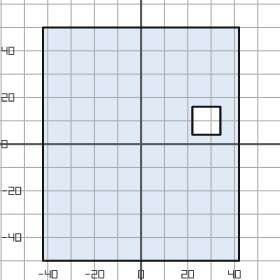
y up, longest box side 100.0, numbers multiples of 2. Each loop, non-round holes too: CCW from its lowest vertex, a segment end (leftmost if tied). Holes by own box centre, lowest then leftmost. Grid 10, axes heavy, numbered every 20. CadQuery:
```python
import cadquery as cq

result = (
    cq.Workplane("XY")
    .moveTo(-42.0, -50.0)
    .lineTo(42.0, -50.0)
    .lineTo(42.0, 50.0)
    .lineTo(-42.0, 50.0)
    .close()
    .moveTo(22.0, 4.0)
    .lineTo(34.0, 4.0)
    .lineTo(34.0, 16.0)
    .lineTo(22.0, 16.0)
    .close()
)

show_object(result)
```